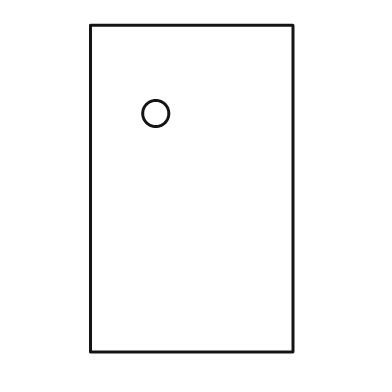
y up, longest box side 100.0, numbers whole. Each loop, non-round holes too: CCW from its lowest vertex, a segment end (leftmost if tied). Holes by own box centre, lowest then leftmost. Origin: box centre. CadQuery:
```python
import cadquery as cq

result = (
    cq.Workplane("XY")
    .moveTo(-31.0, -50.0)
    .lineTo(31.0, -50.0)
    .lineTo(31.0, 50.0)
    .lineTo(-31.0, 50.0)
    .close()
    .moveTo(-11.0, 23.0)
    .circle(4.0)
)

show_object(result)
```